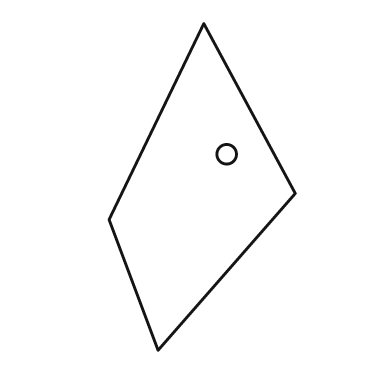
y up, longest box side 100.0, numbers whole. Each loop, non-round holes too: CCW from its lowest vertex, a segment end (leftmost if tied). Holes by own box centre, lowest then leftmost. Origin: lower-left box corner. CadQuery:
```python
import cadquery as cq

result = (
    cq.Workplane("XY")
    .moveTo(15.0, 0.0)
    .lineTo(57.0, 48.0)
    .lineTo(29.0, 100.0)
    .lineTo(0.0, 40.0)
    .close()
    .moveTo(36.0, 60.0)
    .circle(3.0)
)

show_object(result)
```